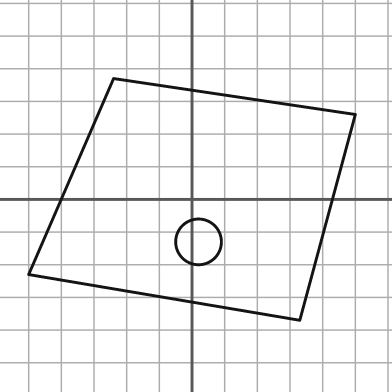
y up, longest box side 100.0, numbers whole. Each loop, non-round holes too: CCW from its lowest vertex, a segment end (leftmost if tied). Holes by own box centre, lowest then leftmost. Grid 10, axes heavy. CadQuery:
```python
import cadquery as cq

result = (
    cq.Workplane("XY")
    .moveTo(33.0, -37.0)
    .lineTo(50.0, 26.0)
    .lineTo(-24.0, 37.0)
    .lineTo(-50.0, -23.0)
    .close()
    .moveTo(2.0, -13.0)
    .circle(7.0)
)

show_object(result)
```